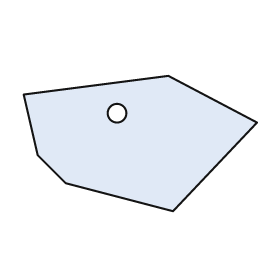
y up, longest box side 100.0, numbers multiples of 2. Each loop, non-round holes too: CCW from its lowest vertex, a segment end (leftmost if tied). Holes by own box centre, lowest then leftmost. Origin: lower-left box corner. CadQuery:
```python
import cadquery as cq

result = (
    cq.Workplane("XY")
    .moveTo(64.0, 0.0)
    .lineTo(100.0, 38.0)
    .lineTo(62.0, 58.0)
    .lineTo(0.0, 50.0)
    .lineTo(6.0, 24.0)
    .lineTo(18.0, 12.0)
    .close()
    .moveTo(40.0, 42.0)
    .circle(4.0)
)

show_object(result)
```